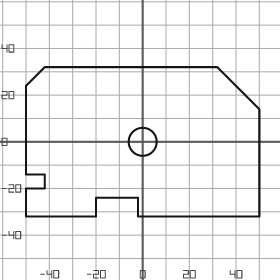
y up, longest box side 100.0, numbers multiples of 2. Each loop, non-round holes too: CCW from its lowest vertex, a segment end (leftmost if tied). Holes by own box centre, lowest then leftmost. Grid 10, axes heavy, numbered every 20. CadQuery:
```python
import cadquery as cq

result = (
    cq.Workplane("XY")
    .moveTo(-50.0, -32.0)
    .lineTo(-20.0, -32.0)
    .lineTo(-20.0, -24.0)
    .lineTo(-2.0, -24.0)
    .lineTo(-2.0, -32.0)
    .lineTo(50.0, -32.0)
    .lineTo(50.0, 14.0)
    .lineTo(32.0, 32.0)
    .lineTo(-42.0, 32.0)
    .lineTo(-50.0, 24.0)
    .lineTo(-50.0, -14.0)
    .lineTo(-42.0, -14.0)
    .lineTo(-42.0, -20.0)
    .lineTo(-50.0, -20.0)
    .close()
    .moveTo(0.0, 0.0)
    .circle(6.0)
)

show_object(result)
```